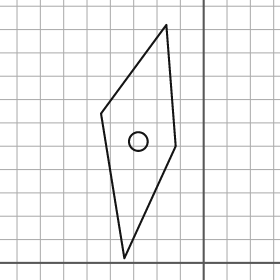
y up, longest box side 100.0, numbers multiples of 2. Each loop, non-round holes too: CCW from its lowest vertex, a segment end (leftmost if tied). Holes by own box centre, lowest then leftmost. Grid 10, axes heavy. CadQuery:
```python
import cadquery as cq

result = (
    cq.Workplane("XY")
    .moveTo(-34.0, 2.0)
    .lineTo(-12.0, 50.0)
    .lineTo(-16.0, 102.0)
    .lineTo(-44.0, 64.0)
    .close()
    .moveTo(-28.0, 52.0)
    .circle(4.0)
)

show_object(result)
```